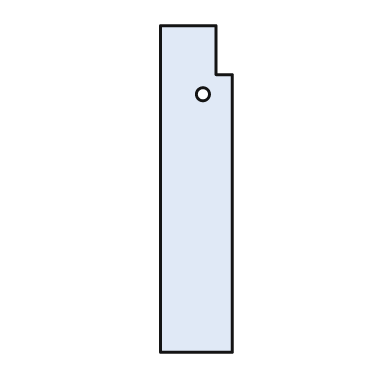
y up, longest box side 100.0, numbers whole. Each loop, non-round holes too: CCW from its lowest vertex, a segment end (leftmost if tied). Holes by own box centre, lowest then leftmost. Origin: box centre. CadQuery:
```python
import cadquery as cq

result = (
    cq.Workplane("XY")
    .moveTo(-11.0, -50.0)
    .lineTo(11.0, -50.0)
    .lineTo(11.0, 35.0)
    .lineTo(6.0, 35.0)
    .lineTo(6.0, 50.0)
    .lineTo(-11.0, 50.0)
    .close()
    .moveTo(2.0, 29.0)
    .circle(2.0)
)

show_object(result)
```